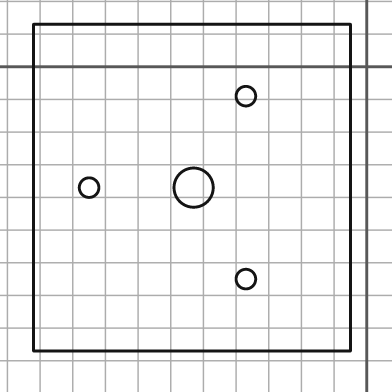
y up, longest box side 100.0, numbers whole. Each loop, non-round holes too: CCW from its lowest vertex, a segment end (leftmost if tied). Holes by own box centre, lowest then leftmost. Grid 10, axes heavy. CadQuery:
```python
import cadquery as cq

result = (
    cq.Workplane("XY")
    .moveTo(-102.0, -87.0)
    .lineTo(-5.0, -87.0)
    .lineTo(-5.0, 13.0)
    .lineTo(-102.0, 13.0)
    .close()
    .moveTo(-37.0, -65.0)
    .circle(3.0)
    .moveTo(-85.0, -37.0)
    .circle(3.0)
    .moveTo(-53.0, -37.0)
    .circle(6.0)
    .moveTo(-37.0, -9.0)
    .circle(3.0)
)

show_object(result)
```